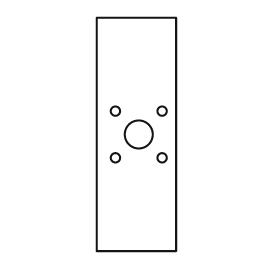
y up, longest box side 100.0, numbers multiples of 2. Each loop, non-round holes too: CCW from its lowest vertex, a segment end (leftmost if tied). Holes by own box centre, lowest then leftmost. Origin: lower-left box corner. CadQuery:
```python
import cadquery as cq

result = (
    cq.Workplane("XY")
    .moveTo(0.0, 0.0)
    .lineTo(34.0, 0.0)
    .lineTo(34.0, 100.0)
    .lineTo(0.0, 100.0)
    .close()
    .moveTo(8.0, 40.0)
    .circle(2.0)
    .moveTo(28.0, 40.0)
    .circle(2.0)
    .moveTo(18.0, 50.0)
    .circle(6.0)
    .moveTo(8.0, 60.0)
    .circle(2.0)
    .moveTo(28.0, 60.0)
    .circle(2.0)
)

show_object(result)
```